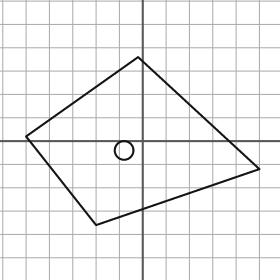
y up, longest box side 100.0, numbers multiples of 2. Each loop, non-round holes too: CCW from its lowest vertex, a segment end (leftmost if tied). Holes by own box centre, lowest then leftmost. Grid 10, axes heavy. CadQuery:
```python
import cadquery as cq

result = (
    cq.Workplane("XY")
    .moveTo(-20.0, -36.0)
    .lineTo(50.0, -12.0)
    .lineTo(-2.0, 36.0)
    .lineTo(-50.0, 2.0)
    .close()
    .moveTo(-8.0, -4.0)
    .circle(4.0)
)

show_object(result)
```